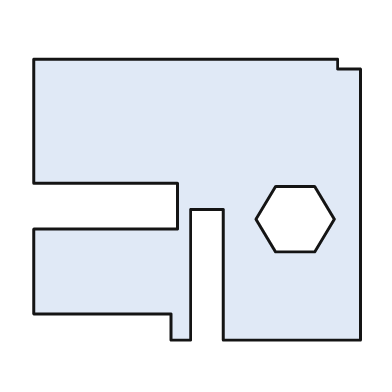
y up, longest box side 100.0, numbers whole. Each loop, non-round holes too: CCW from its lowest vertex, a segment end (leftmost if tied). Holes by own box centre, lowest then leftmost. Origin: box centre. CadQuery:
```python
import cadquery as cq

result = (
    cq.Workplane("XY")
    .moveTo(-8.0, -43.0)
    .lineTo(-2.0, -43.0)
    .lineTo(-2.0, -3.0)
    .lineTo(8.0, -3.0)
    .lineTo(8.0, -43.0)
    .lineTo(50.0, -43.0)
    .lineTo(50.0, 40.0)
    .lineTo(43.0, 40.0)
    .lineTo(43.0, 43.0)
    .lineTo(-50.0, 43.0)
    .lineTo(-50.0, 5.0)
    .lineTo(-6.0, 5.0)
    .lineTo(-6.0, -9.0)
    .lineTo(-50.0, -9.0)
    .lineTo(-50.0, -35.0)
    .lineTo(-8.0, -35.0)
    .close()
    .moveTo(24.0, -16.0)
    .lineTo(36.0, -16.0)
    .lineTo(42.0, -6.0)
    .lineTo(36.0, 4.0)
    .lineTo(24.0, 4.0)
    .lineTo(18.0, -6.0)
    .close()
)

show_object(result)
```